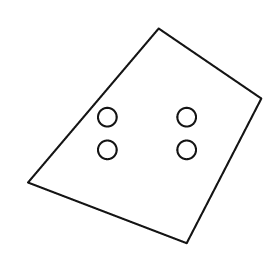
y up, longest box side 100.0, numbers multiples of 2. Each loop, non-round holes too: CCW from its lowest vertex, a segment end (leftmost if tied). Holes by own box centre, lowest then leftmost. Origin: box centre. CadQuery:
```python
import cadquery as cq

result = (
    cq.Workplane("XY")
    .moveTo(18.0, -46.0)
    .lineTo(50.0, 16.0)
    .lineTo(6.0, 46.0)
    .lineTo(-50.0, -20.0)
    .close()
    .moveTo(-16.0, -6.0)
    .circle(4.0)
    .moveTo(18.0, -6.0)
    .circle(4.0)
    .moveTo(-16.0, 8.0)
    .circle(4.0)
    .moveTo(18.0, 8.0)
    .circle(4.0)
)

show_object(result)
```